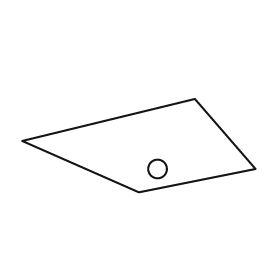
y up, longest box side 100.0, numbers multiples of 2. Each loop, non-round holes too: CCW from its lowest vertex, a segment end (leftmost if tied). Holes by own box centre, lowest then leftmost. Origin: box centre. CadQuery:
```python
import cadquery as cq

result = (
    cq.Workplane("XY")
    .moveTo(0.0, -20.0)
    .lineTo(50.0, -10.0)
    .lineTo(24.0, 20.0)
    .lineTo(-50.0, 2.0)
    .close()
    .moveTo(8.0, -10.0)
    .circle(4.0)
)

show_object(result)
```